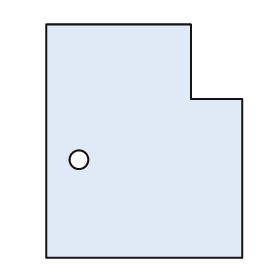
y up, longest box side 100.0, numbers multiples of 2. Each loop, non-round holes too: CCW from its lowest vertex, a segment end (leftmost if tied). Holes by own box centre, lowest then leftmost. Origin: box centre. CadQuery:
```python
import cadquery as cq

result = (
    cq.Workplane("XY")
    .moveTo(-42.0, -50.0)
    .lineTo(42.0, -50.0)
    .lineTo(42.0, 18.0)
    .lineTo(20.0, 18.0)
    .lineTo(20.0, 50.0)
    .lineTo(-42.0, 50.0)
    .close()
    .moveTo(-28.0, -8.0)
    .circle(4.0)
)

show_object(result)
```